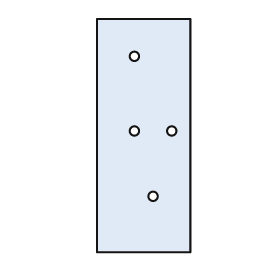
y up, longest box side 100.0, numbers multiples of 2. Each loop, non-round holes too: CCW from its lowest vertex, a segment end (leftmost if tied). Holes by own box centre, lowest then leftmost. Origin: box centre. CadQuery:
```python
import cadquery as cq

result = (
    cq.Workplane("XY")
    .moveTo(-20.0, -50.0)
    .lineTo(20.0, -50.0)
    .lineTo(20.0, 50.0)
    .lineTo(-20.0, 50.0)
    .close()
    .moveTo(4.0, -26.0)
    .circle(2.0)
    .moveTo(-4.0, 2.0)
    .circle(2.0)
    .moveTo(12.0, 2.0)
    .circle(2.0)
    .moveTo(-4.0, 34.0)
    .circle(2.0)
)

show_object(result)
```